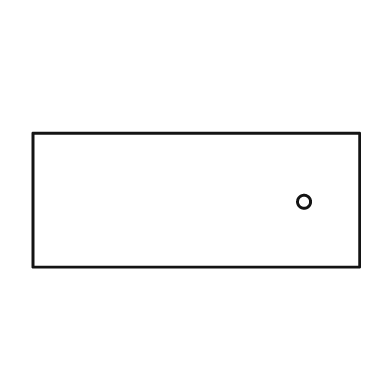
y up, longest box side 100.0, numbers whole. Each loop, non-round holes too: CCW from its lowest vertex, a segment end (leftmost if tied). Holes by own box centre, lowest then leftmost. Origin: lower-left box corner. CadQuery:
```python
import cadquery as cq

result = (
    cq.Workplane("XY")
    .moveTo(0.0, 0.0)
    .lineTo(100.0, 0.0)
    .lineTo(100.0, 41.0)
    .lineTo(0.0, 41.0)
    .close()
    .moveTo(83.0, 20.0)
    .circle(2.0)
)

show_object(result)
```